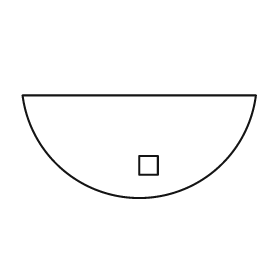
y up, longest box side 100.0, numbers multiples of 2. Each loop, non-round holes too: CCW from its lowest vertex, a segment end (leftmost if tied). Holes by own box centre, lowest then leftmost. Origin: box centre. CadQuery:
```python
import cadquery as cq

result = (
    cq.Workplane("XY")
    .moveTo(-50.0, 22.0)
    .threePointArc((0.0, -22.0), (50.0, 22.0))
    .close()
    .moveTo(0.0, -12.0)
    .lineTo(8.0, -12.0)
    .lineTo(8.0, -4.0)
    .lineTo(0.0, -4.0)
    .close()
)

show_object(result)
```